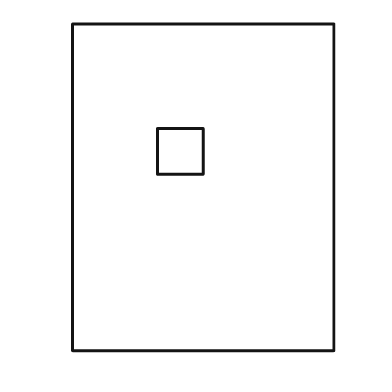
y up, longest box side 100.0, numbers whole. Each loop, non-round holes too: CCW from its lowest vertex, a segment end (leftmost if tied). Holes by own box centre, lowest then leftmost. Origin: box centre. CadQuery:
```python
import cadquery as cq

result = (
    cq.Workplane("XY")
    .moveTo(-40.0, -50.0)
    .lineTo(40.0, -50.0)
    .lineTo(40.0, 50.0)
    .lineTo(-40.0, 50.0)
    .close()
    .moveTo(-14.0, 4.0)
    .lineTo(0.0, 4.0)
    .lineTo(0.0, 18.0)
    .lineTo(-14.0, 18.0)
    .close()
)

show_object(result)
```